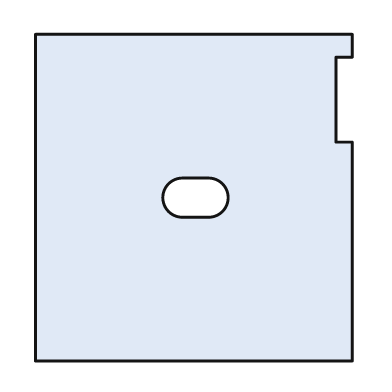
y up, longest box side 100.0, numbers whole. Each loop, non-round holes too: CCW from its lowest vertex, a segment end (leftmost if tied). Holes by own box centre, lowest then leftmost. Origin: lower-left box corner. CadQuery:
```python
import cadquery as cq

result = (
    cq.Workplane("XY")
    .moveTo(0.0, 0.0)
    .lineTo(97.0, 0.0)
    .lineTo(97.0, 67.0)
    .lineTo(92.0, 67.0)
    .lineTo(92.0, 93.0)
    .lineTo(97.0, 93.0)
    .lineTo(97.0, 100.0)
    .lineTo(0.0, 100.0)
    .close()
    .moveTo(45.0, 44.0)
    .lineTo(53.0, 44.0)
    .threePointArc((59.0, 50.0), (53.0, 56.0))
    .lineTo(45.0, 56.0)
    .threePointArc((39.0, 50.0), (45.0, 44.0))
    .close()
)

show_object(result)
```